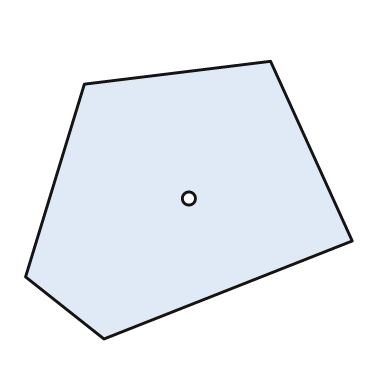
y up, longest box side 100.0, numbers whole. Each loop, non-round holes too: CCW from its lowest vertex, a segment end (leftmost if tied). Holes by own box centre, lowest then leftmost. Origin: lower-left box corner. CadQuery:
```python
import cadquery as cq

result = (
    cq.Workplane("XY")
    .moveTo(24.0, 0.0)
    .lineTo(100.0, 30.0)
    .lineTo(75.0, 85.0)
    .lineTo(18.0, 78.0)
    .lineTo(0.0, 19.0)
    .close()
    .moveTo(50.0, 43.0)
    .circle(2.0)
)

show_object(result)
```